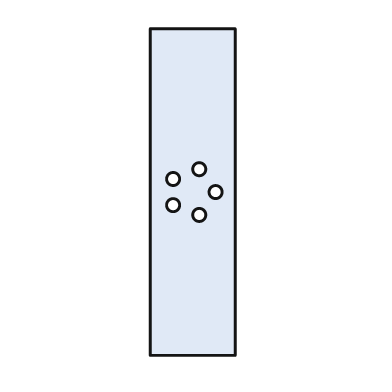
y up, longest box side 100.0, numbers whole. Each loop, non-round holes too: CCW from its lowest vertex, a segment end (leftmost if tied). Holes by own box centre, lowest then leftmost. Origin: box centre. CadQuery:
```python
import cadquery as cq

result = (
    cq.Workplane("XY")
    .moveTo(-13.0, -50.0)
    .lineTo(13.0, -50.0)
    .lineTo(13.0, 50.0)
    .lineTo(-13.0, 50.0)
    .close()
    .moveTo(2.0, -7.0)
    .circle(2.0)
    .moveTo(-6.0, -4.0)
    .circle(2.0)
    .moveTo(7.0, 0.0)
    .circle(2.0)
    .moveTo(-6.0, 4.0)
    .circle(2.0)
    .moveTo(2.0, 7.0)
    .circle(2.0)
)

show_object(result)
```